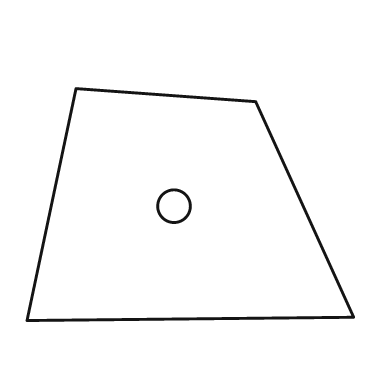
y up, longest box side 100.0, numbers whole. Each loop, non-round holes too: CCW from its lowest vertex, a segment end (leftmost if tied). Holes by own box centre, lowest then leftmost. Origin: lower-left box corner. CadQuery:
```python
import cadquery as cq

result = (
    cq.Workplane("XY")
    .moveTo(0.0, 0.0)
    .lineTo(100.0, 1.0)
    .lineTo(70.0, 67.0)
    .lineTo(15.0, 71.0)
    .close()
    .moveTo(45.0, 35.0)
    .circle(5.0)
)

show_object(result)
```